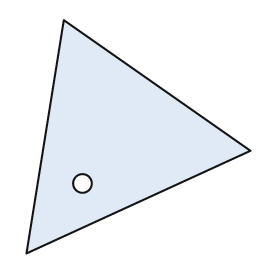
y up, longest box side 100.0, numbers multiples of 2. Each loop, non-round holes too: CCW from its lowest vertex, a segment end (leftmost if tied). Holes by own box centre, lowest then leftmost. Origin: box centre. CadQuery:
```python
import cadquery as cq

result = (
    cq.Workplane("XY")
    .moveTo(-48.0, -50.0)
    .lineTo(48.0, -6.0)
    .lineTo(-32.0, 50.0)
    .close()
    .moveTo(-24.0, -20.0)
    .circle(4.0)
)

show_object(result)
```